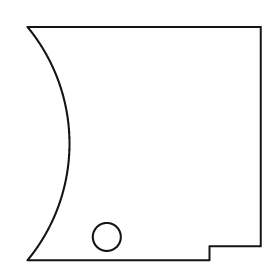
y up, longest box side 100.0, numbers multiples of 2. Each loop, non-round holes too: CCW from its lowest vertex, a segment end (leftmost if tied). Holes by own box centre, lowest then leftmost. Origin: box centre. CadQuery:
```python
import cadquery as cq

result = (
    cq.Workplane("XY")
    .moveTo(-50.0, -50.0)
    .lineTo(28.0, -50.0)
    .lineTo(28.0, -44.0)
    .lineTo(50.0, -44.0)
    .lineTo(50.0, 50.0)
    .lineTo(-50.0, 50.0)
    .threePointArc((-32.0, 0.0), (-50.0, -50.0))
    .close()
    .moveTo(-16.0, -40.0)
    .circle(6.0)
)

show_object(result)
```